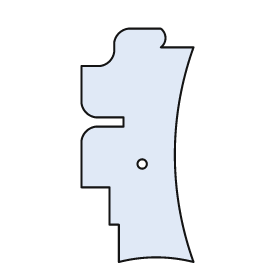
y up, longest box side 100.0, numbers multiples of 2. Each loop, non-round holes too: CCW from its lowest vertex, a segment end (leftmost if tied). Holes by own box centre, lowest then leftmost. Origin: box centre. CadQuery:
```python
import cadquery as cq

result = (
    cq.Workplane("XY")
    .moveTo(-8.0, -50.0)
    .threePointArc((8.0, -48.0), (24.0, -50.0))
    .threePointArc((16.0, -4.0), (24.0, 42.0))
    .lineTo(10.0, 42.0)
    .threePointArc((12.0, 46.0), (10.0, 50.0))
    .lineTo(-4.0, 50.0)
    .threePointArc((-8.0, 48.0), (-10.0, 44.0))
    .lineTo(-10.0, 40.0)
    .threePointArc((-12.0, 36.0), (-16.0, 34.0))
    .lineTo(-24.0, 34.0)
    .lineTo(-24.0, 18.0)
    .threePointArc((-22.0, 14.0), (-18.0, 12.0))
    .lineTo(-6.0, 12.0)
    .lineTo(-6.0, 8.0)
    .lineTo(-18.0, 8.0)
    .threePointArc((-22.0, 6.0), (-24.0, 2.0))
    .lineTo(-24.0, -18.0)
    .lineTo(-12.0, -18.0)
    .lineTo(-12.0, -34.0)
    .lineTo(-8.0, -34.0)
    .close()
    .moveTo(2.0, -8.0)
    .circle(2.0)
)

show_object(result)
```